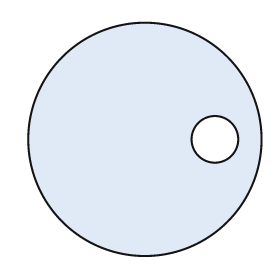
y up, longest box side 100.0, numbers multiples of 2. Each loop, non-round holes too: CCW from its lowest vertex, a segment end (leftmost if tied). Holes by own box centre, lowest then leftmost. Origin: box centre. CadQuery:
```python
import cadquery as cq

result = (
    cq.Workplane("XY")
    .moveTo(0.0, 0.0)
    .circle(50.0)
    .moveTo(30.0, 0.0)
    .circle(10.0)
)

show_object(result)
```